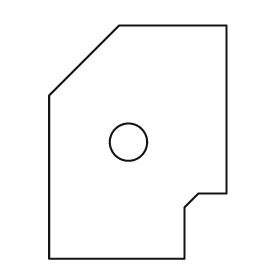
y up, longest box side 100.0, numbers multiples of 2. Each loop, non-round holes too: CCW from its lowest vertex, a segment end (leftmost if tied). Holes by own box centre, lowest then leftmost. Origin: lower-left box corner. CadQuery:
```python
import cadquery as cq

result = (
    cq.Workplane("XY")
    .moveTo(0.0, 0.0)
    .lineTo(58.0, 0.0)
    .lineTo(58.0, 22.0)
    .lineTo(64.0, 28.0)
    .lineTo(76.0, 28.0)
    .lineTo(76.0, 100.0)
    .lineTo(30.0, 100.0)
    .lineTo(0.0, 70.0)
    .close()
    .moveTo(34.0, 50.0)
    .circle(8.0)
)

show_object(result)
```